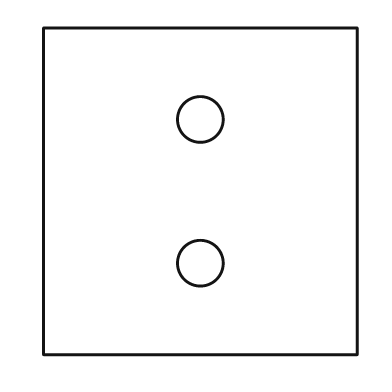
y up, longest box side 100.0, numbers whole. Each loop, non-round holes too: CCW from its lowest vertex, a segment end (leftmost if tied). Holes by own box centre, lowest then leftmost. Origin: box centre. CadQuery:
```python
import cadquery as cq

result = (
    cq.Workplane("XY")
    .moveTo(-48.0, -50.0)
    .lineTo(48.0, -50.0)
    .lineTo(48.0, 50.0)
    .lineTo(-48.0, 50.0)
    .close()
    .moveTo(0.0, -22.0)
    .circle(7.0)
    .moveTo(0.0, 22.0)
    .circle(7.0)
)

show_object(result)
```